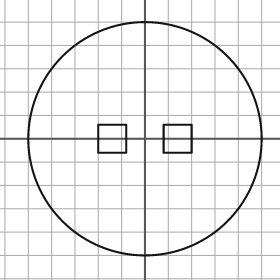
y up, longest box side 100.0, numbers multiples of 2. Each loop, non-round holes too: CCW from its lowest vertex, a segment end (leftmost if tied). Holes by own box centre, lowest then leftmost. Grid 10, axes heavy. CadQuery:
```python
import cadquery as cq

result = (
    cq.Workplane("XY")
    .moveTo(0.0, 0.0)
    .circle(50.0)
    .moveTo(-20.0, -6.0)
    .lineTo(-8.0, -6.0)
    .lineTo(-8.0, 6.0)
    .lineTo(-20.0, 6.0)
    .close()
    .moveTo(8.0, -6.0)
    .lineTo(20.0, -6.0)
    .lineTo(20.0, 6.0)
    .lineTo(8.0, 6.0)
    .close()
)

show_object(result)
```